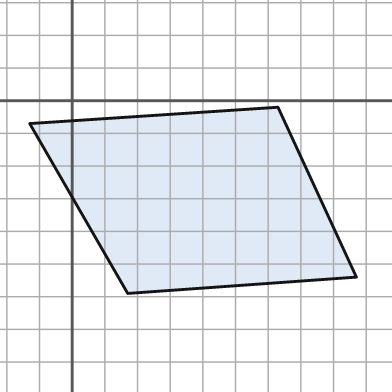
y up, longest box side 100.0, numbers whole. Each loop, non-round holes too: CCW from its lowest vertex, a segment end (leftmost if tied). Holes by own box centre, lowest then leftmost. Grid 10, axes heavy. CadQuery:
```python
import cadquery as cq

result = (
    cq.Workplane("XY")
    .moveTo(17.0, -59.0)
    .lineTo(87.0, -54.0)
    .lineTo(63.0, -2.0)
    .lineTo(-13.0, -7.0)
    .close()
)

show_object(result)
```